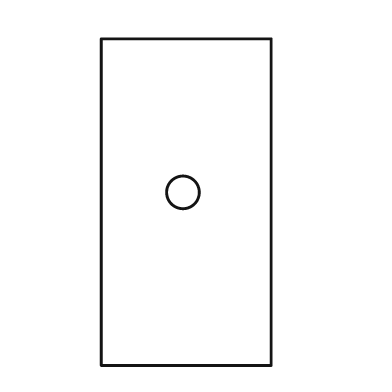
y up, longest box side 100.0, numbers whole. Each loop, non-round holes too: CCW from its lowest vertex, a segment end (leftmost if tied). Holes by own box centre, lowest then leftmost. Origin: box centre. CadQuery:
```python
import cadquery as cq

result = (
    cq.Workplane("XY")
    .moveTo(-26.0, -50.0)
    .lineTo(26.0, -50.0)
    .lineTo(26.0, 50.0)
    .lineTo(-26.0, 50.0)
    .close()
    .moveTo(-1.0, 3.0)
    .circle(5.0)
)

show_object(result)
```